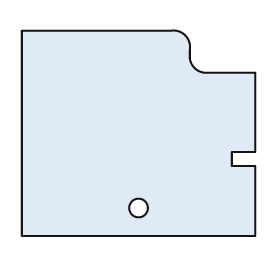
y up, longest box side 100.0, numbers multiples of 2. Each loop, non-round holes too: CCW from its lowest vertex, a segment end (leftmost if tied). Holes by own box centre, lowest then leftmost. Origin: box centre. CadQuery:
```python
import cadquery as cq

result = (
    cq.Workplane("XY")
    .moveTo(-50.0, -44.0)
    .lineTo(50.0, -44.0)
    .lineTo(50.0, -14.0)
    .lineTo(40.0, -14.0)
    .lineTo(40.0, -8.0)
    .lineTo(50.0, -8.0)
    .lineTo(50.0, 26.0)
    .lineTo(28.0, 26.0)
    .threePointArc((24.0, 28.0), (22.0, 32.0))
    .lineTo(22.0, 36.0)
    .threePointArc((20.0, 42.0), (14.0, 44.0))
    .lineTo(-50.0, 44.0)
    .close()
    .moveTo(0.0, -32.0)
    .circle(4.0)
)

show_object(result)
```